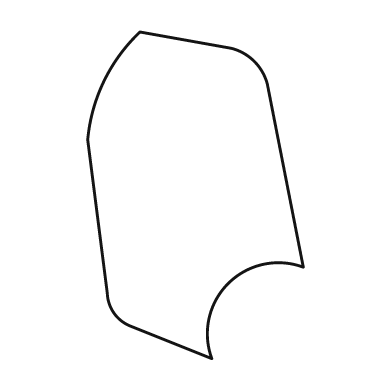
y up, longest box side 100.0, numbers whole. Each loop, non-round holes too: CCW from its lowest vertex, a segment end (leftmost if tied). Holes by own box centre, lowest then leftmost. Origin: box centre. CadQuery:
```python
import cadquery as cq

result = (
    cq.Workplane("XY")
    .moveTo(5.0, -50.0)
    .threePointArc((10.0, -27.0), (33.0, -22.0))
    .lineTo(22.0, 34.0)
    .threePointArc((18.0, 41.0), (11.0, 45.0))
    .lineTo(-17.0, 50.0)
    .threePointArc((-28.0, 35.0), (-33.0, 17.0))
    .lineTo(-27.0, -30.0)
    .threePointArc((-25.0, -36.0), (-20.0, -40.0))
    .close()
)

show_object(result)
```